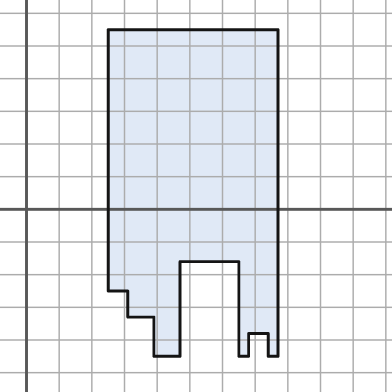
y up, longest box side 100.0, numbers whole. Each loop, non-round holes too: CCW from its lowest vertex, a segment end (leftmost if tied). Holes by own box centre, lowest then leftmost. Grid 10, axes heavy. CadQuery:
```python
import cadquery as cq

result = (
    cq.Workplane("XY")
    .moveTo(39.0, -45.0)
    .lineTo(47.0, -45.0)
    .lineTo(47.0, -16.0)
    .lineTo(65.0, -16.0)
    .lineTo(65.0, -45.0)
    .lineTo(68.0, -45.0)
    .lineTo(68.0, -38.0)
    .lineTo(74.0, -38.0)
    .lineTo(74.0, -45.0)
    .lineTo(77.0, -45.0)
    .lineTo(77.0, 55.0)
    .lineTo(25.0, 55.0)
    .lineTo(25.0, -25.0)
    .lineTo(31.0, -25.0)
    .lineTo(31.0, -33.0)
    .lineTo(39.0, -33.0)
    .close()
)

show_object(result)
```